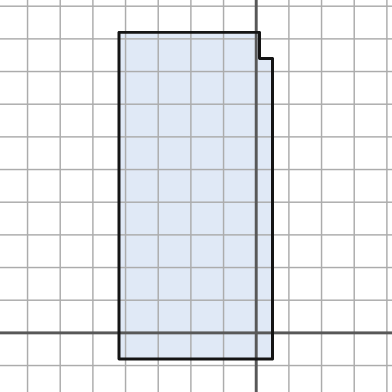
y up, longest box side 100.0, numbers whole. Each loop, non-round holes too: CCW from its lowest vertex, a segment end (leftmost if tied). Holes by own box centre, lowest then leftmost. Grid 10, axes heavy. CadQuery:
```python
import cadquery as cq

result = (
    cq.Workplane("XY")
    .moveTo(-42.0, -8.0)
    .lineTo(5.0, -8.0)
    .lineTo(5.0, 84.0)
    .lineTo(1.0, 84.0)
    .lineTo(1.0, 92.0)
    .lineTo(-42.0, 92.0)
    .close()
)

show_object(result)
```